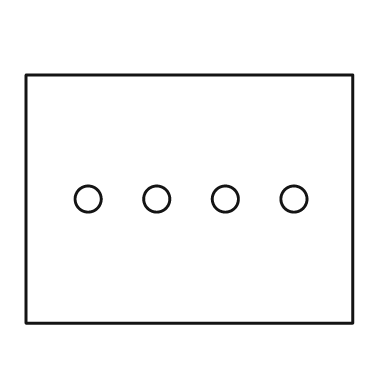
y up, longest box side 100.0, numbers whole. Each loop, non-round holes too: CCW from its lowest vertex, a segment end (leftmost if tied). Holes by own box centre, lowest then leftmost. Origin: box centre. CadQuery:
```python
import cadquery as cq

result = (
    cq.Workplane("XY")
    .moveTo(-50.0, -38.0)
    .lineTo(50.0, -38.0)
    .lineTo(50.0, 38.0)
    .lineTo(-50.0, 38.0)
    .close()
    .moveTo(-31.0, 0.0)
    .circle(4.0)
    .moveTo(-10.0, 0.0)
    .circle(4.0)
    .moveTo(11.0, 0.0)
    .circle(4.0)
    .moveTo(32.0, 0.0)
    .circle(4.0)
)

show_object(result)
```